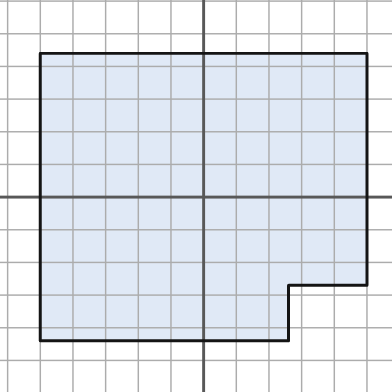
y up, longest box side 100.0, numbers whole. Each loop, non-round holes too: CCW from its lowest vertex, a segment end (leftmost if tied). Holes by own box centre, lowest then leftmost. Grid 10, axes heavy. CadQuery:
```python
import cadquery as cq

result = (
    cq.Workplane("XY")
    .moveTo(-50.0, -44.0)
    .lineTo(26.0, -44.0)
    .lineTo(26.0, -27.0)
    .lineTo(50.0, -27.0)
    .lineTo(50.0, 44.0)
    .lineTo(-50.0, 44.0)
    .close()
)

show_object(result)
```